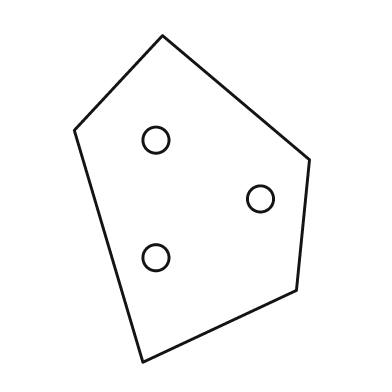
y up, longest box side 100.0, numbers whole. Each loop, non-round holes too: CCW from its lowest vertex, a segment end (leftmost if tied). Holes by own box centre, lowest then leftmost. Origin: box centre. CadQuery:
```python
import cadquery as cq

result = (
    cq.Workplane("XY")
    .moveTo(-15.0, -50.0)
    .lineTo(32.0, -28.0)
    .lineTo(36.0, 12.0)
    .lineTo(-9.0, 50.0)
    .lineTo(-36.0, 21.0)
    .close()
    .moveTo(-11.0, -18.0)
    .circle(4.0)
    .moveTo(21.0, 0.0)
    .circle(4.0)
    .moveTo(-11.0, 18.0)
    .circle(4.0)
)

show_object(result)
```